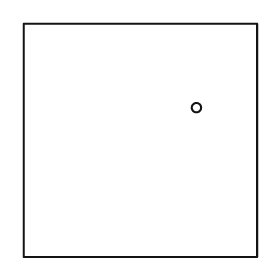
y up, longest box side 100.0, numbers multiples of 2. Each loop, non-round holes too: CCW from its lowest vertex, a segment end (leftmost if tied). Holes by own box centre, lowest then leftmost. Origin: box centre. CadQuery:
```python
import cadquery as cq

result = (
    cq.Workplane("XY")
    .moveTo(-50.0, -50.0)
    .lineTo(50.0, -50.0)
    .lineTo(50.0, 50.0)
    .lineTo(-50.0, 50.0)
    .close()
    .moveTo(24.0, 14.0)
    .circle(2.0)
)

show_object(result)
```